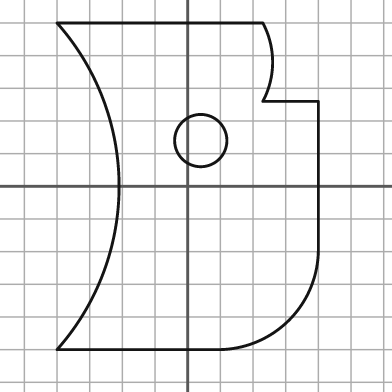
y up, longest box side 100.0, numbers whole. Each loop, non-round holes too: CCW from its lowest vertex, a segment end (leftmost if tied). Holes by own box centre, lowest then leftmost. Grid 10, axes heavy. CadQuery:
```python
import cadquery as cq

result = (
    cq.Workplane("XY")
    .moveTo(-40.0, -50.0)
    .lineTo(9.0, -50.0)
    .threePointArc((31.0, -41.0), (40.0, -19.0))
    .lineTo(40.0, 26.0)
    .lineTo(23.0, 26.0)
    .threePointArc((26.0, 38.0), (23.0, 50.0))
    .lineTo(-40.0, 50.0)
    .threePointArc((-21.0, 0.0), (-40.0, -50.0))
    .close()
    .moveTo(4.0, 14.0)
    .circle(8.0)
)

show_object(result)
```